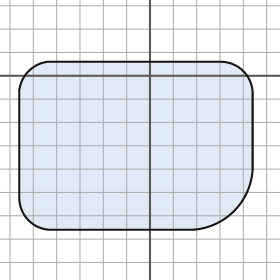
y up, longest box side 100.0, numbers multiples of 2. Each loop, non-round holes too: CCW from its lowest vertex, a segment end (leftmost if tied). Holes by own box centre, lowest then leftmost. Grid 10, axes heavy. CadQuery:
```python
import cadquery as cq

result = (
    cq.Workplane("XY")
    .moveTo(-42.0, -66.0)
    .lineTo(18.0, -66.0)
    .threePointArc((36.0, -58.0), (44.0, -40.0))
    .lineTo(44.0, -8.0)
    .threePointArc((40.0, 2.0), (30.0, 6.0))
    .lineTo(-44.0, 6.0)
    .threePointArc((-52.0, 2.0), (-56.0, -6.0))
    .lineTo(-56.0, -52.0)
    .threePointArc((-52.0, -62.0), (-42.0, -66.0))
    .close()
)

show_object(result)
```